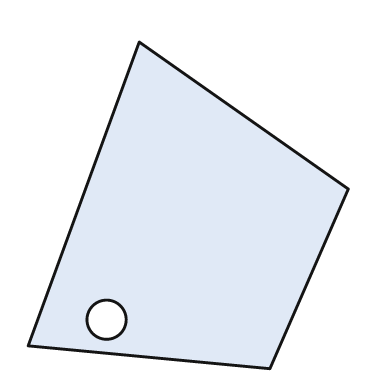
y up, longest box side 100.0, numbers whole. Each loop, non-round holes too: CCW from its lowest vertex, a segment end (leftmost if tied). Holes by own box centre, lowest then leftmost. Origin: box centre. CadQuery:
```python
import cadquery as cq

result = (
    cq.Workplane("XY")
    .moveTo(25.0, -50.0)
    .lineTo(49.0, 5.0)
    .lineTo(-15.0, 50.0)
    .lineTo(-49.0, -43.0)
    .close()
    .moveTo(-25.0, -35.0)
    .circle(6.0)
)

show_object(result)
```